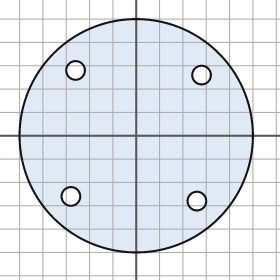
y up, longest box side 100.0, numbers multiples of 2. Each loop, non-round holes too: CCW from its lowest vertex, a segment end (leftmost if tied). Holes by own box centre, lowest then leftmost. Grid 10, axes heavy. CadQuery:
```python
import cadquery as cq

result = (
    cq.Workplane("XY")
    .moveTo(0.0, 0.0)
    .circle(50.0)
    .moveTo(26.0, -28.0)
    .circle(4.0)
    .moveTo(-28.0, -26.0)
    .circle(4.0)
    .moveTo(28.0, 26.0)
    .circle(4.0)
    .moveTo(-26.0, 28.0)
    .circle(4.0)
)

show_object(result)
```